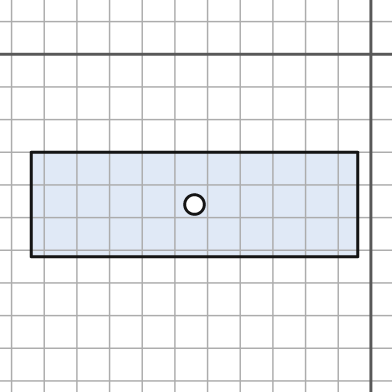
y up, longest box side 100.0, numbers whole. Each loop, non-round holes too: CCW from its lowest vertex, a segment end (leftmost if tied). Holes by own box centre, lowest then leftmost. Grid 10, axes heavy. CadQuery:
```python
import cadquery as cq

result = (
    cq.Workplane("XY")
    .moveTo(-104.0, -62.0)
    .lineTo(-4.0, -62.0)
    .lineTo(-4.0, -30.0)
    .lineTo(-104.0, -30.0)
    .close()
    .moveTo(-54.0, -46.0)
    .circle(3.0)
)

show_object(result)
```